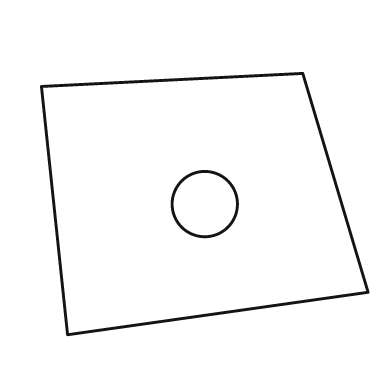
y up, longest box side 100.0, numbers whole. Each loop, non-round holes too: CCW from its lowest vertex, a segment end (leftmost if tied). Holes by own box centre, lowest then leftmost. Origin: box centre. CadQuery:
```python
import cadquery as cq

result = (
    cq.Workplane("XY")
    .moveTo(-42.0, -40.0)
    .lineTo(50.0, -27.0)
    .lineTo(30.0, 40.0)
    .lineTo(-50.0, 36.0)
    .close()
    .moveTo(0.0, 0.0)
    .circle(10.0)
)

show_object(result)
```